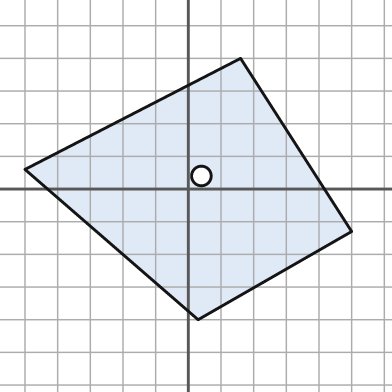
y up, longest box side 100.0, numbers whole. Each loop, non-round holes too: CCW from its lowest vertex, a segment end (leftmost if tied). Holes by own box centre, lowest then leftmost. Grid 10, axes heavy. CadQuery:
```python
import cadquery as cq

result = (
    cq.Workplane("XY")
    .moveTo(3.0, -40.0)
    .lineTo(50.0, -13.0)
    .lineTo(16.0, 40.0)
    .lineTo(-50.0, 6.0)
    .close()
    .moveTo(4.0, 4.0)
    .circle(3.0)
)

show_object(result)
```